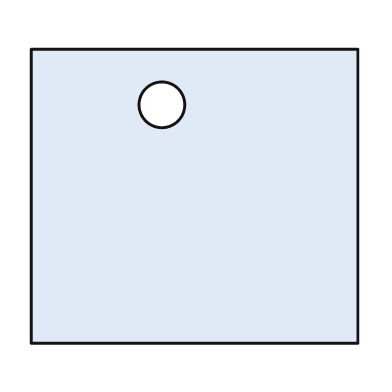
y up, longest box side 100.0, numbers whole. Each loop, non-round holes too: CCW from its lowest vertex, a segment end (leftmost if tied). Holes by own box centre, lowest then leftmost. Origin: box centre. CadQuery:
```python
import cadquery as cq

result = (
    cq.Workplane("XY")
    .moveTo(-50.0, -45.0)
    .lineTo(50.0, -45.0)
    .lineTo(50.0, 45.0)
    .lineTo(-50.0, 45.0)
    .close()
    .moveTo(-10.0, 28.0)
    .circle(7.0)
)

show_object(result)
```